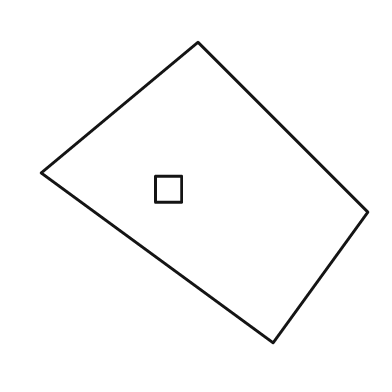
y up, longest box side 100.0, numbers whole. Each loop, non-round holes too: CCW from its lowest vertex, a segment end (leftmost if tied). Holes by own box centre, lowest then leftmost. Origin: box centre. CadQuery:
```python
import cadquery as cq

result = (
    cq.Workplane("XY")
    .moveTo(21.0, -46.0)
    .lineTo(50.0, -6.0)
    .lineTo(-2.0, 46.0)
    .lineTo(-50.0, 6.0)
    .close()
    .moveTo(-15.0, -3.0)
    .lineTo(-7.0, -3.0)
    .lineTo(-7.0, 5.0)
    .lineTo(-15.0, 5.0)
    .close()
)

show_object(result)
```